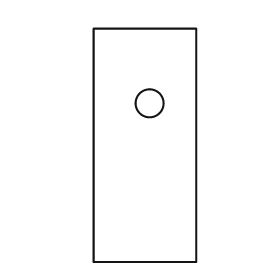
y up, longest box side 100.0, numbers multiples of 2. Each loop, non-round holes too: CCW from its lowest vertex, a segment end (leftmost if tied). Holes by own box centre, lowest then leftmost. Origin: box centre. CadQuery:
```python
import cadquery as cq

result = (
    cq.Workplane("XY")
    .moveTo(-22.0, -50.0)
    .lineTo(22.0, -50.0)
    .lineTo(22.0, 50.0)
    .lineTo(-22.0, 50.0)
    .close()
    .moveTo(2.0, 18.0)
    .circle(6.0)
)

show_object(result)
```